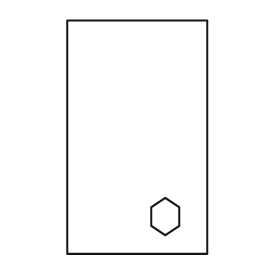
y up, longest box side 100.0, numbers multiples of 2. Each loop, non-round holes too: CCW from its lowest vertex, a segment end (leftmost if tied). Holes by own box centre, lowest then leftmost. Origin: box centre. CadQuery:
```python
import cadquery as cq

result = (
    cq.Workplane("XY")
    .moveTo(-30.0, -50.0)
    .lineTo(30.0, -50.0)
    .lineTo(30.0, 50.0)
    .lineTo(-30.0, 50.0)
    .close()
    .moveTo(12.0, -42.0)
    .lineTo(18.0, -38.0)
    .lineTo(18.0, -30.0)
    .lineTo(12.0, -26.0)
    .lineTo(6.0, -30.0)
    .lineTo(6.0, -38.0)
    .close()
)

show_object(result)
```